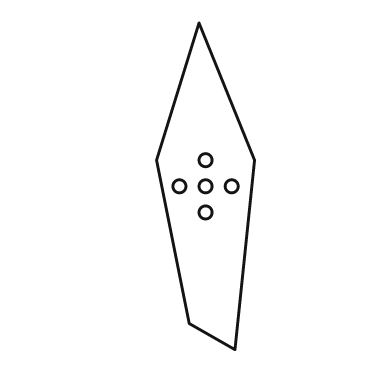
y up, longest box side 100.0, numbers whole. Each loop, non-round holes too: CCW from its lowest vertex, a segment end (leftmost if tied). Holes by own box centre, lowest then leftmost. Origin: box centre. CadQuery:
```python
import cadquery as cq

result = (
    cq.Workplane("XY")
    .moveTo(9.0, -50.0)
    .lineTo(15.0, 8.0)
    .lineTo(-2.0, 50.0)
    .lineTo(-15.0, 8.0)
    .lineTo(-5.0, -42.0)
    .close()
    .moveTo(0.0, -8.0)
    .circle(2.0)
    .moveTo(-8.0, 0.0)
    .circle(2.0)
    .moveTo(0.0, 0.0)
    .circle(2.0)
    .moveTo(8.0, 0.0)
    .circle(2.0)
    .moveTo(0.0, 8.0)
    .circle(2.0)
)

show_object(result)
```